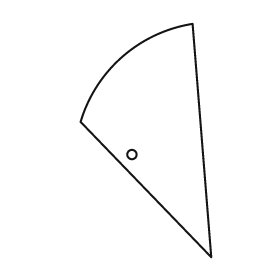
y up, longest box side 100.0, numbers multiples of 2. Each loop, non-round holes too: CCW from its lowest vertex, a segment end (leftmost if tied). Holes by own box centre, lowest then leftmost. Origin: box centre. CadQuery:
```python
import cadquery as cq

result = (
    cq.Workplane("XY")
    .moveTo(28.0, -50.0)
    .lineTo(20.0, 50.0)
    .threePointArc((-10.0, 36.0), (-28.0, 8.0))
    .close()
    .moveTo(-6.0, -6.0)
    .circle(2.0)
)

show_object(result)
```